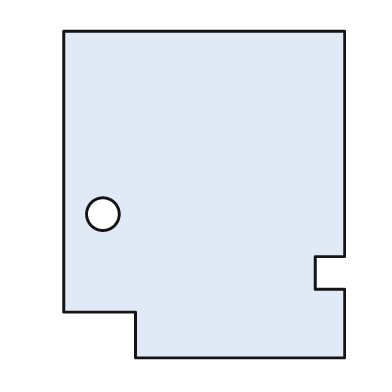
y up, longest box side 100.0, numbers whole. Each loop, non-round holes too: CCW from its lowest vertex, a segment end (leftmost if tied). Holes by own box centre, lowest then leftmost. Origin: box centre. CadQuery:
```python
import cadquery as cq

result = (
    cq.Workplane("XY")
    .moveTo(-21.0, -50.0)
    .lineTo(43.0, -50.0)
    .lineTo(43.0, -29.0)
    .lineTo(34.0, -29.0)
    .lineTo(34.0, -19.0)
    .lineTo(43.0, -19.0)
    .lineTo(43.0, 50.0)
    .lineTo(-43.0, 50.0)
    .lineTo(-43.0, -36.0)
    .lineTo(-21.0, -36.0)
    .close()
    .moveTo(-31.0, -6.0)
    .circle(5.0)
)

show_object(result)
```